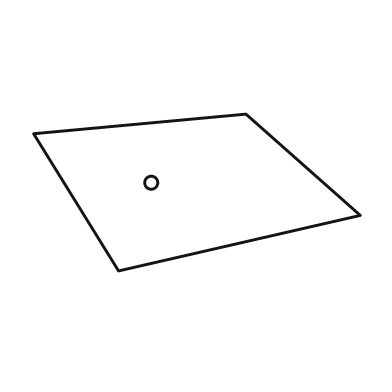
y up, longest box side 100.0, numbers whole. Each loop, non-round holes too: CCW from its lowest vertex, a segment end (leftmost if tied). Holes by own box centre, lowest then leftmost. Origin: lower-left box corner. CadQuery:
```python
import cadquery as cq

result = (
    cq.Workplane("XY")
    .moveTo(26.0, 0.0)
    .lineTo(100.0, 17.0)
    .lineTo(65.0, 48.0)
    .lineTo(0.0, 42.0)
    .close()
    .moveTo(36.0, 27.0)
    .circle(2.0)
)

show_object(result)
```